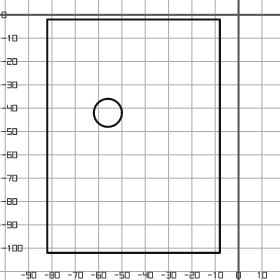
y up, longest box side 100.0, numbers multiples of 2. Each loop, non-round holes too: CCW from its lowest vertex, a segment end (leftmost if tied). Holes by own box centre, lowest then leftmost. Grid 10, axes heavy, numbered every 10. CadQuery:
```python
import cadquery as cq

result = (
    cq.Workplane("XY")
    .moveTo(-82.0, -102.0)
    .lineTo(-8.0, -102.0)
    .lineTo(-8.0, -2.0)
    .lineTo(-82.0, -2.0)
    .close()
    .moveTo(-56.0, -42.0)
    .circle(6.0)
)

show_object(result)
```